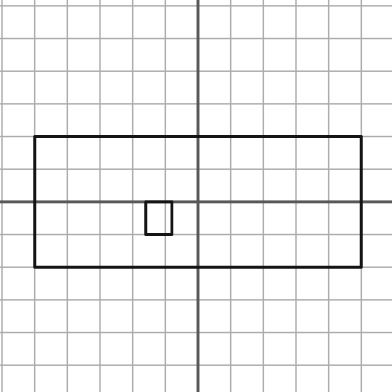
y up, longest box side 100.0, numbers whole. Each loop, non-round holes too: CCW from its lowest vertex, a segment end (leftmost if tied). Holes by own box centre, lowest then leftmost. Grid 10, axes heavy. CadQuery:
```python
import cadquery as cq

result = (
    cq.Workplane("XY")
    .moveTo(-50.0, -20.0)
    .lineTo(50.0, -20.0)
    .lineTo(50.0, 20.0)
    .lineTo(-50.0, 20.0)
    .close()
    .moveTo(-16.0, -10.0)
    .lineTo(-8.0, -10.0)
    .lineTo(-8.0, 0.0)
    .lineTo(-16.0, 0.0)
    .close()
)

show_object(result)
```